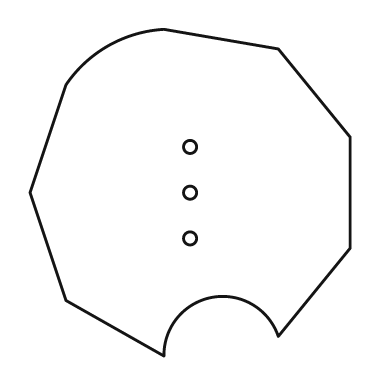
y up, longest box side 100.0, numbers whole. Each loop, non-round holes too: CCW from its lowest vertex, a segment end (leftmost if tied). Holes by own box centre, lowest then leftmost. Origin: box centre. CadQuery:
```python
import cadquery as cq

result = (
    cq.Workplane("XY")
    .moveTo(-8.0, -50.0)
    .threePointArc((7.0, -32.0), (27.0, -44.0))
    .lineTo(49.0, -17.0)
    .lineTo(49.0, 17.0)
    .lineTo(27.0, 44.0)
    .lineTo(-8.0, 50.0)
    .threePointArc((-25.0, 45.0), (-38.0, 33.0))
    .lineTo(-49.0, 0.0)
    .lineTo(-38.0, -33.0)
    .close()
    .moveTo(0.0, -14.0)
    .circle(2.0)
    .moveTo(0.0, 0.0)
    .circle(2.0)
    .moveTo(0.0, 14.0)
    .circle(2.0)
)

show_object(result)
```